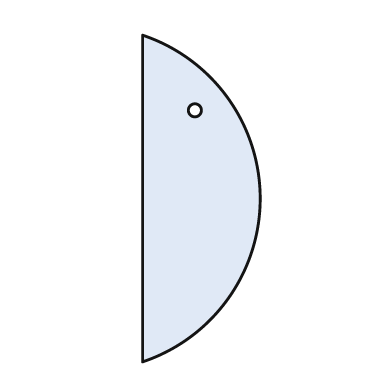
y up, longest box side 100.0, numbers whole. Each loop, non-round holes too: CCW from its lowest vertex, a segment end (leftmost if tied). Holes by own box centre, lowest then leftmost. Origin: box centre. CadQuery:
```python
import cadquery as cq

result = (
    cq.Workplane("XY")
    .moveTo(-18.0, -50.0)
    .threePointArc((18.0, 0.0), (-18.0, 50.0))
    .close()
    .moveTo(-2.0, 27.0)
    .circle(2.0)
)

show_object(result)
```